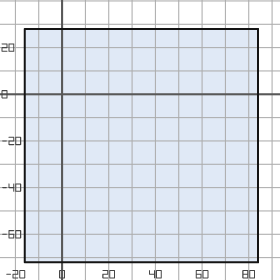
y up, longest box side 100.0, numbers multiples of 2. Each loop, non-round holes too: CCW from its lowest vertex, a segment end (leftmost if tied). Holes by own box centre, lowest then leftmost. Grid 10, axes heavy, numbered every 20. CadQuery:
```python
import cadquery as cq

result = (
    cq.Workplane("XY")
    .moveTo(-16.0, -72.0)
    .lineTo(84.0, -72.0)
    .lineTo(84.0, 28.0)
    .lineTo(-16.0, 28.0)
    .close()
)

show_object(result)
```